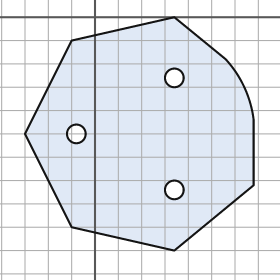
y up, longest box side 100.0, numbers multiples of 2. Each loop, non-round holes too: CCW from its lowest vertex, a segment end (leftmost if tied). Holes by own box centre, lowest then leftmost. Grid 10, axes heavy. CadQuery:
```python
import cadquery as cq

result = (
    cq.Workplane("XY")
    .moveTo(34.0, -100.0)
    .lineTo(68.0, -72.0)
    .lineTo(68.0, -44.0)
    .threePointArc((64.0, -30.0), (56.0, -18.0))
    .lineTo(34.0, 0.0)
    .lineTo(-10.0, -10.0)
    .lineTo(-30.0, -50.0)
    .lineTo(-10.0, -90.0)
    .close()
    .moveTo(34.0, -74.0)
    .circle(4.0)
    .moveTo(-8.0, -50.0)
    .circle(4.0)
    .moveTo(34.0, -26.0)
    .circle(4.0)
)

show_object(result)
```